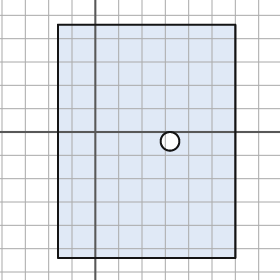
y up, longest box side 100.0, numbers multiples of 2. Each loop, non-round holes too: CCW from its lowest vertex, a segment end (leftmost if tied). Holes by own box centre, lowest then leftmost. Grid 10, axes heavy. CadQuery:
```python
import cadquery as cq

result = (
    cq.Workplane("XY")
    .moveTo(-16.0, -54.0)
    .lineTo(60.0, -54.0)
    .lineTo(60.0, 46.0)
    .lineTo(-16.0, 46.0)
    .close()
    .moveTo(32.0, -4.0)
    .circle(4.0)
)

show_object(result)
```